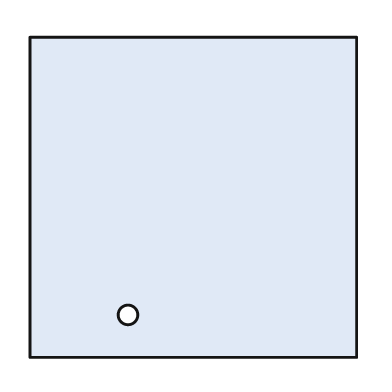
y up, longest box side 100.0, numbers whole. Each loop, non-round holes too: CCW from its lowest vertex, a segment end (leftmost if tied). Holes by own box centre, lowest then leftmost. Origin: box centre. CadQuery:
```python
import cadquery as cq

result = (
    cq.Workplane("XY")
    .moveTo(-50.0, -49.0)
    .lineTo(50.0, -49.0)
    .lineTo(50.0, 49.0)
    .lineTo(-50.0, 49.0)
    .close()
    .moveTo(-20.0, -36.0)
    .circle(3.0)
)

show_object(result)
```